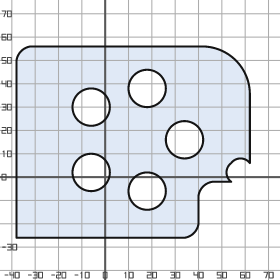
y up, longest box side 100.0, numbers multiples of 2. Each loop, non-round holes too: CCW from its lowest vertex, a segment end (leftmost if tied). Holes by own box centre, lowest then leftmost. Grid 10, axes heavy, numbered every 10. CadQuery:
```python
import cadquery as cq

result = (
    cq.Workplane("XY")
    .moveTo(-38.0, -26.0)
    .lineTo(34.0, -26.0)
    .threePointArc((38.0, -24.0), (40.0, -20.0))
    .lineTo(40.0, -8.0)
    .threePointArc((42.0, -4.0), (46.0, -2.0))
    .lineTo(54.0, -2.0)
    .threePointArc((52.0, 2.0), (54.0, 6.0))
    .threePointArc((58.0, 8.0), (62.0, 6.0))
    .lineTo(62.0, 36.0)
    .threePointArc((56.0, 50.0), (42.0, 56.0))
    .lineTo(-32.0, 56.0)
    .threePointArc((-36.0, 54.0), (-38.0, 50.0))
    .close()
    .moveTo(18.0, -6.0)
    .circle(8.0)
    .moveTo(-6.0, 2.0)
    .circle(8.0)
    .moveTo(34.0, 16.0)
    .circle(8.0)
    .moveTo(-6.0, 30.0)
    .circle(8.0)
    .moveTo(18.0, 38.0)
    .circle(8.0)
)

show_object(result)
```